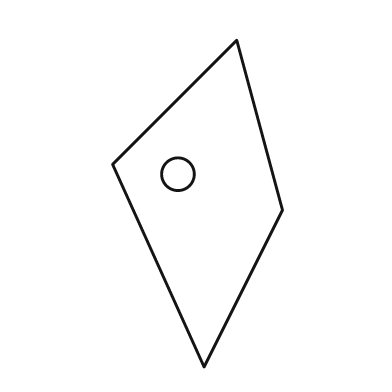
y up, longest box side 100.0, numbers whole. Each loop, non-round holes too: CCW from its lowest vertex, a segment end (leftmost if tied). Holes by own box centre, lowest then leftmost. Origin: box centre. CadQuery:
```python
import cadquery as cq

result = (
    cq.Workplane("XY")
    .moveTo(2.0, -50.0)
    .lineTo(26.0, -2.0)
    .lineTo(12.0, 50.0)
    .lineTo(-26.0, 12.0)
    .close()
    .moveTo(-6.0, 9.0)
    .circle(5.0)
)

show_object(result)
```